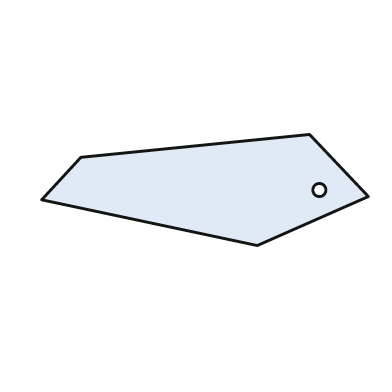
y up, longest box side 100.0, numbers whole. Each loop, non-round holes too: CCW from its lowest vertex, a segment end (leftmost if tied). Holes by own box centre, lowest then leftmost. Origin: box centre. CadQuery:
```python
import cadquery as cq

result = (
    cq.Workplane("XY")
    .moveTo(16.0, -17.0)
    .lineTo(50.0, -2.0)
    .lineTo(32.0, 17.0)
    .lineTo(-38.0, 10.0)
    .lineTo(-50.0, -3.0)
    .close()
    .moveTo(35.0, 0.0)
    .circle(2.0)
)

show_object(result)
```